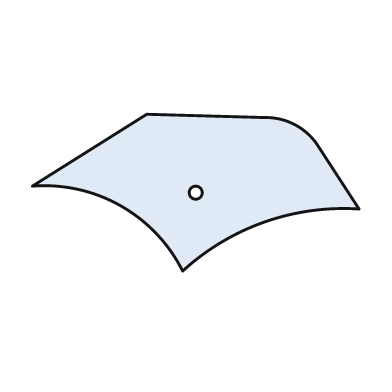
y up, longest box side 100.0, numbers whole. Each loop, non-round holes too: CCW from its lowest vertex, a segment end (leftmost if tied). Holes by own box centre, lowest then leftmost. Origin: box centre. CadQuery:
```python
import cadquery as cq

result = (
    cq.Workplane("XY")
    .moveTo(-4.0, -24.0)
    .threePointArc((21.0, -9.0), (50.0, -5.0))
    .lineTo(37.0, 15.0)
    .threePointArc((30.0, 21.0), (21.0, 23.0))
    .lineTo(-15.0, 24.0)
    .lineTo(-50.0, 2.0)
    .threePointArc((-23.0, -4.0), (-4.0, -24.0))
    .close()
    .moveTo(0.0, 0.0)
    .circle(2.0)
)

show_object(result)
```